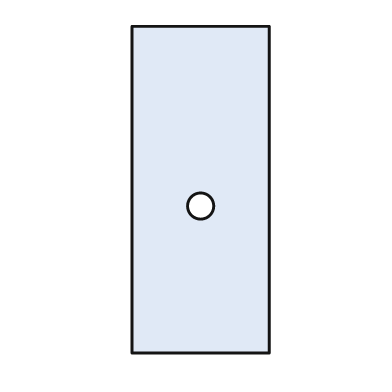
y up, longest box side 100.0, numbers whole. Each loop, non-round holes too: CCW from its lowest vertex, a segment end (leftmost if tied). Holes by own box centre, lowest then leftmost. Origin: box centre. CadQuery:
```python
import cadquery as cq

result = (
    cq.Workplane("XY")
    .moveTo(-21.0, -50.0)
    .lineTo(21.0, -50.0)
    .lineTo(21.0, 50.0)
    .lineTo(-21.0, 50.0)
    .close()
    .moveTo(0.0, -5.0)
    .circle(4.0)
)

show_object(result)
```